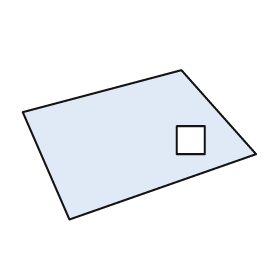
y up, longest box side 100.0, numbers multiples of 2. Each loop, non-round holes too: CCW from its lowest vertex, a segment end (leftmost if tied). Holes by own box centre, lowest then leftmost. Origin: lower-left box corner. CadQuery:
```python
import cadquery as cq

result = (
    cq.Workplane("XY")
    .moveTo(20.0, 0.0)
    .lineTo(100.0, 28.0)
    .lineTo(68.0, 64.0)
    .lineTo(0.0, 46.0)
    .close()
    .moveTo(66.0, 28.0)
    .lineTo(78.0, 28.0)
    .lineTo(78.0, 40.0)
    .lineTo(66.0, 40.0)
    .close()
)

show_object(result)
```